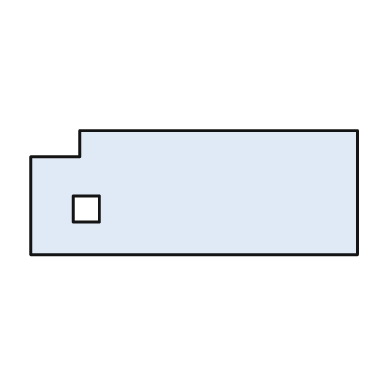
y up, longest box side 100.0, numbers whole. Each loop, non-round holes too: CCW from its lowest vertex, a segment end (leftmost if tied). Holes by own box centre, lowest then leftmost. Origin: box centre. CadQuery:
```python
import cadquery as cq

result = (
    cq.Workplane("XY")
    .moveTo(-50.0, -19.0)
    .lineTo(50.0, -19.0)
    .lineTo(50.0, 19.0)
    .lineTo(-35.0, 19.0)
    .lineTo(-35.0, 11.0)
    .lineTo(-50.0, 11.0)
    .close()
    .moveTo(-37.0, -9.0)
    .lineTo(-29.0, -9.0)
    .lineTo(-29.0, -1.0)
    .lineTo(-37.0, -1.0)
    .close()
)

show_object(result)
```